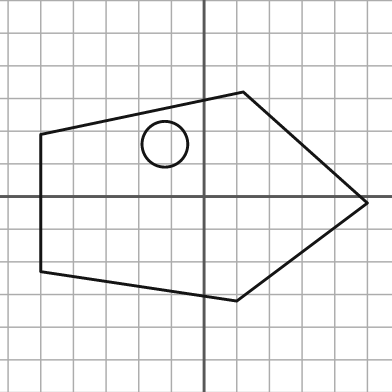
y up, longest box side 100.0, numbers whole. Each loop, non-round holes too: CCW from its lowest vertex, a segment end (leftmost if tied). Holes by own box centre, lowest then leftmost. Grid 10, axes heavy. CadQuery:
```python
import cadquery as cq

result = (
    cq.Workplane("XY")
    .moveTo(10.0, -32.0)
    .lineTo(50.0, -2.0)
    .lineTo(12.0, 32.0)
    .lineTo(-50.0, 19.0)
    .lineTo(-50.0, -23.0)
    .close()
    .moveTo(-12.0, 16.0)
    .circle(7.0)
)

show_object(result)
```